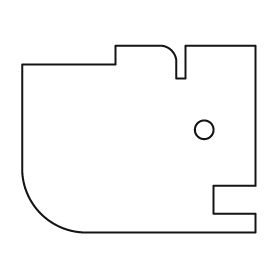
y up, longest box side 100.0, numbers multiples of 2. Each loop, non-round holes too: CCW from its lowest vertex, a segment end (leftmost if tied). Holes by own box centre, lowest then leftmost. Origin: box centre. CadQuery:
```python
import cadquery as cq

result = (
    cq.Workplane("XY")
    .moveTo(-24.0, -40.0)
    .lineTo(50.0, -40.0)
    .lineTo(50.0, -32.0)
    .lineTo(32.0, -32.0)
    .lineTo(32.0, -20.0)
    .lineTo(50.0, -20.0)
    .lineTo(50.0, 40.0)
    .lineTo(20.0, 40.0)
    .lineTo(20.0, 26.0)
    .lineTo(16.0, 26.0)
    .lineTo(16.0, 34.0)
    .threePointArc((14.0, 38.0), (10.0, 40.0))
    .lineTo(-10.0, 40.0)
    .lineTo(-10.0, 32.0)
    .lineTo(-50.0, 32.0)
    .lineTo(-50.0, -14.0)
    .threePointArc((-42.0, -32.0), (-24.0, -40.0))
    .close()
    .moveTo(28.0, 4.0)
    .circle(4.0)
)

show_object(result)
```